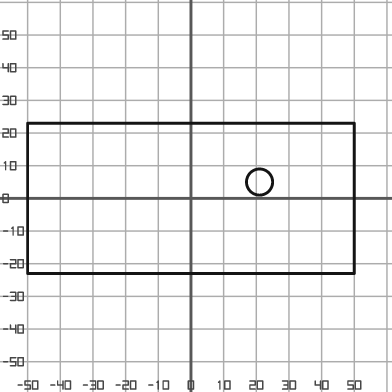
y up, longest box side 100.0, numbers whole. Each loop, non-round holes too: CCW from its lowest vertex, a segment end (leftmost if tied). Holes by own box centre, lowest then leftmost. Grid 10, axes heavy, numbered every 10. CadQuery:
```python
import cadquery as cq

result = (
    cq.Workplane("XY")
    .moveTo(-50.0, -23.0)
    .lineTo(50.0, -23.0)
    .lineTo(50.0, 23.0)
    .lineTo(-50.0, 23.0)
    .close()
    .moveTo(21.0, 5.0)
    .circle(4.0)
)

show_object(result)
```